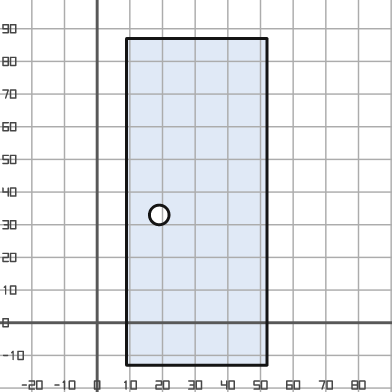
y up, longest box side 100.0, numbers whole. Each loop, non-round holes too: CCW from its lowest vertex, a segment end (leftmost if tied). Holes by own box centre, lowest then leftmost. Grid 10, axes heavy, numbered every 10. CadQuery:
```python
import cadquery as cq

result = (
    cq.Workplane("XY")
    .moveTo(9.0, -13.0)
    .lineTo(52.0, -13.0)
    .lineTo(52.0, 87.0)
    .lineTo(9.0, 87.0)
    .close()
    .moveTo(19.0, 33.0)
    .circle(3.0)
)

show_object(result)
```